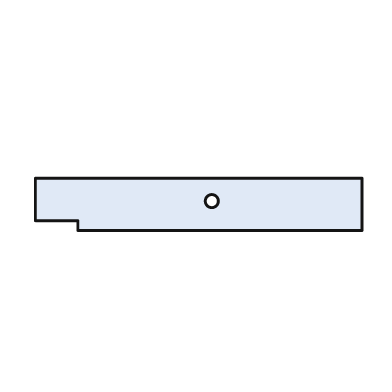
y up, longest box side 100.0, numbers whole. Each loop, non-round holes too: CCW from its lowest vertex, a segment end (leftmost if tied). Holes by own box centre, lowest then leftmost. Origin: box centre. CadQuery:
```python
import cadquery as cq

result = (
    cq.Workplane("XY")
    .moveTo(-37.0, -8.0)
    .lineTo(50.0, -8.0)
    .lineTo(50.0, 8.0)
    .lineTo(-50.0, 8.0)
    .lineTo(-50.0, -5.0)
    .lineTo(-37.0, -5.0)
    .close()
    .moveTo(4.0, 1.0)
    .circle(2.0)
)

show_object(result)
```